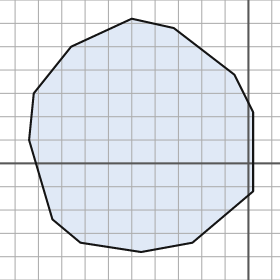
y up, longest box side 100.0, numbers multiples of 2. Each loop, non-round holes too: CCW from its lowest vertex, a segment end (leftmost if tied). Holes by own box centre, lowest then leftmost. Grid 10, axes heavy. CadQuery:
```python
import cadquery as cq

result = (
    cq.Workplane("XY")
    .moveTo(-46.0, -38.0)
    .lineTo(-24.0, -34.0)
    .lineTo(2.0, -12.0)
    .lineTo(2.0, 22.0)
    .lineTo(-6.0, 38.0)
    .lineTo(-32.0, 58.0)
    .lineTo(-50.0, 62.0)
    .lineTo(-76.0, 50.0)
    .lineTo(-92.0, 30.0)
    .lineTo(-94.0, 10.0)
    .lineTo(-84.0, -24.0)
    .lineTo(-72.0, -34.0)
    .close()
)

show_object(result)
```